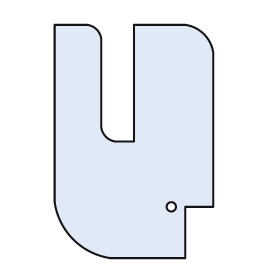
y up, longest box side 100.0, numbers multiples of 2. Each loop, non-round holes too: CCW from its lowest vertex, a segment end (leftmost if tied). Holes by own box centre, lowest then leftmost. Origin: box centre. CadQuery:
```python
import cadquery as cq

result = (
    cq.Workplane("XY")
    .moveTo(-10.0, -50.0)
    .lineTo(22.0, -50.0)
    .lineTo(22.0, -28.0)
    .lineTo(34.0, -28.0)
    .lineTo(34.0, 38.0)
    .threePointArc((30.0, 46.0), (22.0, 50.0))
    .lineTo(0.0, 50.0)
    .lineTo(0.0, 0.0)
    .lineTo(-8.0, 0.0)
    .threePointArc((-12.0, 2.0), (-14.0, 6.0))
    .lineTo(-14.0, 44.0)
    .threePointArc((-16.0, 48.0), (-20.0, 50.0))
    .lineTo(-34.0, 50.0)
    .lineTo(-34.0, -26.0)
    .threePointArc((-26.0, -42.0), (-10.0, -50.0))
    .close()
    .moveTo(16.0, -28.0)
    .circle(2.0)
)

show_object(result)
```